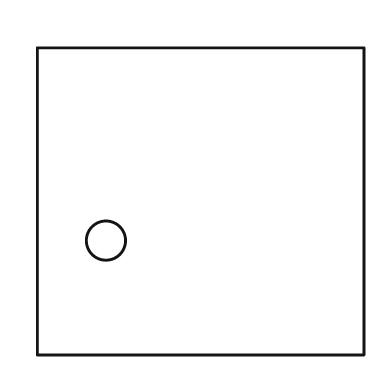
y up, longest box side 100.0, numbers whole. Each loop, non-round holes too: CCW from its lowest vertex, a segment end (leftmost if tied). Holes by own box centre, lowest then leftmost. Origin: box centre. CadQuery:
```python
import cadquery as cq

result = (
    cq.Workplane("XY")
    .moveTo(-50.0, -47.0)
    .lineTo(50.0, -47.0)
    .lineTo(50.0, 47.0)
    .lineTo(-50.0, 47.0)
    .close()
    .moveTo(-29.0, -12.0)
    .circle(6.0)
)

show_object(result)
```